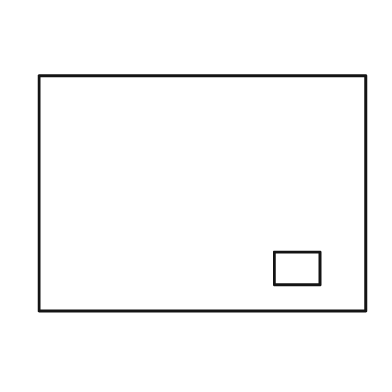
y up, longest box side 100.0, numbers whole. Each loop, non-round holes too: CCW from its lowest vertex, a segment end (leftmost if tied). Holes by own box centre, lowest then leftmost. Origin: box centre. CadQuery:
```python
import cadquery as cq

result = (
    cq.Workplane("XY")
    .moveTo(-50.0, -36.0)
    .lineTo(50.0, -36.0)
    .lineTo(50.0, 36.0)
    .lineTo(-50.0, 36.0)
    .close()
    .moveTo(22.0, -28.0)
    .lineTo(36.0, -28.0)
    .lineTo(36.0, -18.0)
    .lineTo(22.0, -18.0)
    .close()
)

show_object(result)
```